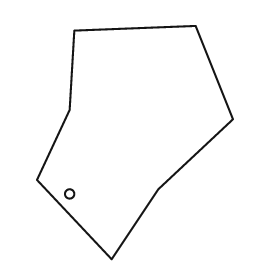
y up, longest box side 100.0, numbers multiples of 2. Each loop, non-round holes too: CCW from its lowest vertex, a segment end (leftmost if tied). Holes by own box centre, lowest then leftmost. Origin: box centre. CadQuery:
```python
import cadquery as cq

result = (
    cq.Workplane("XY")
    .moveTo(-10.0, -50.0)
    .lineTo(10.0, -20.0)
    .lineTo(42.0, 10.0)
    .lineTo(26.0, 50.0)
    .lineTo(-26.0, 48.0)
    .lineTo(-28.0, 14.0)
    .lineTo(-42.0, -16.0)
    .close()
    .moveTo(-28.0, -22.0)
    .circle(2.0)
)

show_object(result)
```